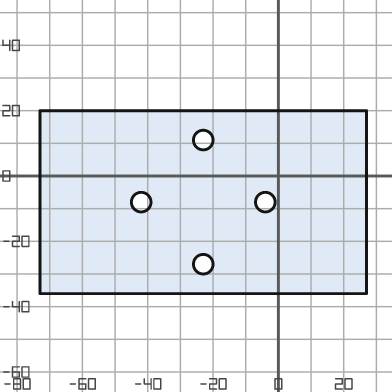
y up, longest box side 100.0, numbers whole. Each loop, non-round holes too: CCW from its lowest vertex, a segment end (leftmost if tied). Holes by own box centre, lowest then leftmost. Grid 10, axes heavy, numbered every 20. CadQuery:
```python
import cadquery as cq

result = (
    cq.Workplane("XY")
    .moveTo(-73.0, -36.0)
    .lineTo(27.0, -36.0)
    .lineTo(27.0, 20.0)
    .lineTo(-73.0, 20.0)
    .close()
    .moveTo(-23.0, -27.0)
    .circle(3.0)
    .moveTo(-42.0, -8.0)
    .circle(3.0)
    .moveTo(-4.0, -8.0)
    .circle(3.0)
    .moveTo(-23.0, 11.0)
    .circle(3.0)
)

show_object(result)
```